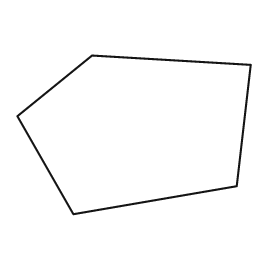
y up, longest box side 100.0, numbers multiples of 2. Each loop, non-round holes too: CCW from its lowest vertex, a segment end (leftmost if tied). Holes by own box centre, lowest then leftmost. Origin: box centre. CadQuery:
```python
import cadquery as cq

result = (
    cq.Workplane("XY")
    .moveTo(-26.0, -34.0)
    .lineTo(44.0, -22.0)
    .lineTo(50.0, 30.0)
    .lineTo(-18.0, 34.0)
    .lineTo(-50.0, 8.0)
    .close()
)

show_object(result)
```